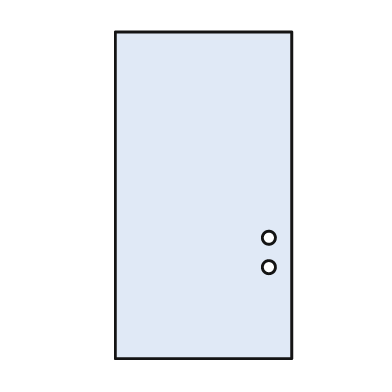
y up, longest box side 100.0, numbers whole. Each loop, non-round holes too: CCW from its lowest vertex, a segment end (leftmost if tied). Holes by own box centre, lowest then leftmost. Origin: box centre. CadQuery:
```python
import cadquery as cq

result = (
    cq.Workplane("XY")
    .moveTo(-27.0, -50.0)
    .lineTo(27.0, -50.0)
    .lineTo(27.0, 50.0)
    .lineTo(-27.0, 50.0)
    .close()
    .moveTo(20.0, -22.0)
    .circle(2.0)
    .moveTo(20.0, -13.0)
    .circle(2.0)
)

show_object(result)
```